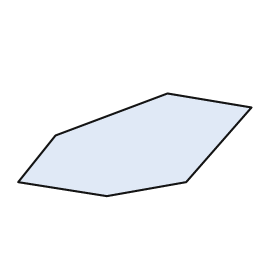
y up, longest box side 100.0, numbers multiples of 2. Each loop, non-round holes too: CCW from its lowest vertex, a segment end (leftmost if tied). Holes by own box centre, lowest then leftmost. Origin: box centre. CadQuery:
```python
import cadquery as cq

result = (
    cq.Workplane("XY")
    .moveTo(-12.0, -22.0)
    .lineTo(22.0, -16.0)
    .lineTo(50.0, 16.0)
    .lineTo(14.0, 22.0)
    .lineTo(-34.0, 4.0)
    .lineTo(-50.0, -16.0)
    .close()
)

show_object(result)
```